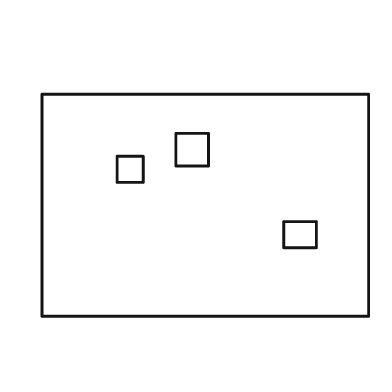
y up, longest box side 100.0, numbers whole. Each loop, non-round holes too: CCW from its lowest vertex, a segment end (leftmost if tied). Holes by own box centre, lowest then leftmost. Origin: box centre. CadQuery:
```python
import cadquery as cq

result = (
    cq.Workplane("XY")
    .moveTo(-50.0, -34.0)
    .lineTo(50.0, -34.0)
    .lineTo(50.0, 34.0)
    .lineTo(-50.0, 34.0)
    .close()
    .moveTo(24.0, -13.0)
    .lineTo(34.0, -13.0)
    .lineTo(34.0, -5.0)
    .lineTo(24.0, -5.0)
    .close()
    .moveTo(-27.0, 7.0)
    .lineTo(-19.0, 7.0)
    .lineTo(-19.0, 15.0)
    .lineTo(-27.0, 15.0)
    .close()
    .moveTo(-9.0, 12.0)
    .lineTo(1.0, 12.0)
    .lineTo(1.0, 22.0)
    .lineTo(-9.0, 22.0)
    .close()
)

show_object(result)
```